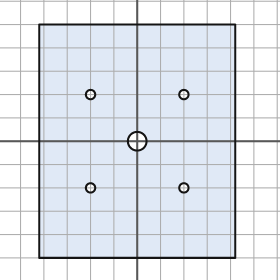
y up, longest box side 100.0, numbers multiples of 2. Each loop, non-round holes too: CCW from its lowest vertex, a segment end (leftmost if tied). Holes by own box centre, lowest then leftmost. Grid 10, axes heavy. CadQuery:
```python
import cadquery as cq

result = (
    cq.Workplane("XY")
    .moveTo(-42.0, -50.0)
    .lineTo(42.0, -50.0)
    .lineTo(42.0, 50.0)
    .lineTo(-42.0, 50.0)
    .close()
    .moveTo(-20.0, -20.0)
    .circle(2.0)
    .moveTo(20.0, -20.0)
    .circle(2.0)
    .moveTo(0.0, 0.0)
    .circle(4.0)
    .moveTo(-20.0, 20.0)
    .circle(2.0)
    .moveTo(20.0, 20.0)
    .circle(2.0)
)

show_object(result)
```